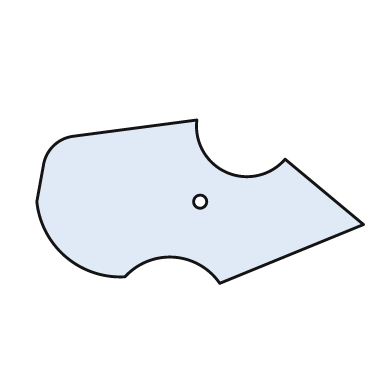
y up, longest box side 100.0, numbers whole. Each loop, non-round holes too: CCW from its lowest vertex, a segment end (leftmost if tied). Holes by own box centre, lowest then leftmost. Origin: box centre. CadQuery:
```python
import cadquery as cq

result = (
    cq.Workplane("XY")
    .moveTo(6.0, -25.0)
    .lineTo(50.0, -7.0)
    .lineTo(26.0, 13.0)
    .threePointArc((8.0, 9.0), (-1.0, 25.0))
    .lineTo(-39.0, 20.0)
    .threePointArc((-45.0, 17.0), (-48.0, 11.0))
    .lineTo(-50.0, 0.0)
    .threePointArc((-41.0, -17.0), (-23.0, -23.0))
    .threePointArc((-8.0, -17.0), (6.0, -25.0))
    .close()
    .moveTo(0.0, 0.0)
    .circle(2.0)
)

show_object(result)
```